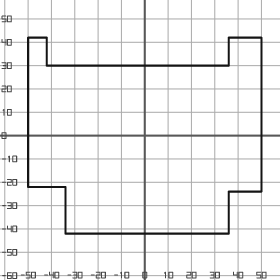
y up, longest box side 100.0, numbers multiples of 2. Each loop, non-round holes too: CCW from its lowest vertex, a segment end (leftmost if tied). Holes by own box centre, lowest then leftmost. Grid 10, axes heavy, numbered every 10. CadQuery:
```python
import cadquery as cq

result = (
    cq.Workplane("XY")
    .moveTo(-34.0, -42.0)
    .lineTo(36.0, -42.0)
    .lineTo(36.0, -24.0)
    .lineTo(50.0, -24.0)
    .lineTo(50.0, 42.0)
    .lineTo(36.0, 42.0)
    .lineTo(36.0, 30.0)
    .lineTo(-42.0, 30.0)
    .lineTo(-42.0, 42.0)
    .lineTo(-50.0, 42.0)
    .lineTo(-50.0, -22.0)
    .lineTo(-34.0, -22.0)
    .close()
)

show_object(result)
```